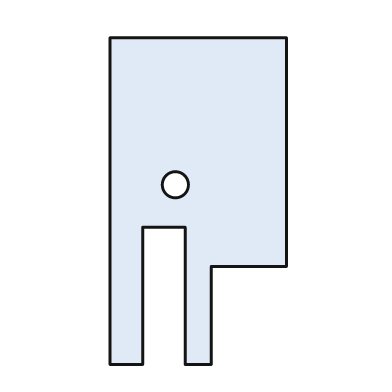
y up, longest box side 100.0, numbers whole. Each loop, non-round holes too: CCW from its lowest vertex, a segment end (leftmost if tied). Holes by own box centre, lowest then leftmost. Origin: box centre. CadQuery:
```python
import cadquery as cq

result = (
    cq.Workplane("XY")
    .moveTo(-27.0, -50.0)
    .lineTo(-17.0, -50.0)
    .lineTo(-17.0, -8.0)
    .lineTo(-4.0, -8.0)
    .lineTo(-4.0, -50.0)
    .lineTo(4.0, -50.0)
    .lineTo(4.0, -20.0)
    .lineTo(27.0, -20.0)
    .lineTo(27.0, 50.0)
    .lineTo(-27.0, 50.0)
    .close()
    .moveTo(-7.0, 5.0)
    .circle(4.0)
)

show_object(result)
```